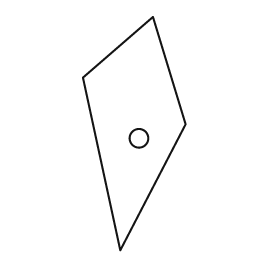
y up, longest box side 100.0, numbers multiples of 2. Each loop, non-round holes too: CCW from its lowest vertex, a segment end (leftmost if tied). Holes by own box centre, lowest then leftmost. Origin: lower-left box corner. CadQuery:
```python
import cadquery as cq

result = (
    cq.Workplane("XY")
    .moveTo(16.0, 0.0)
    .lineTo(44.0, 54.0)
    .lineTo(30.0, 100.0)
    .lineTo(0.0, 74.0)
    .close()
    .moveTo(24.0, 48.0)
    .circle(4.0)
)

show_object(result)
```